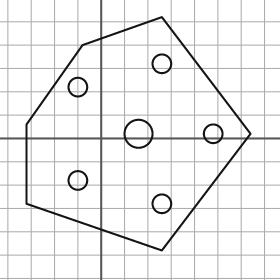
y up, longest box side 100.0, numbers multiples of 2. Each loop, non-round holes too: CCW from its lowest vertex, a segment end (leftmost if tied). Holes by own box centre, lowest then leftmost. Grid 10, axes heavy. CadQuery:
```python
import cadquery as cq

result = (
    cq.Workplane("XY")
    .moveTo(26.0, -48.0)
    .lineTo(64.0, 2.0)
    .lineTo(26.0, 52.0)
    .lineTo(-8.0, 40.0)
    .lineTo(-32.0, 6.0)
    .lineTo(-32.0, -28.0)
    .close()
    .moveTo(26.0, -28.0)
    .circle(4.0)
    .moveTo(-10.0, -18.0)
    .circle(4.0)
    .moveTo(16.0, 2.0)
    .circle(6.0)
    .moveTo(48.0, 2.0)
    .circle(4.0)
    .moveTo(-10.0, 22.0)
    .circle(4.0)
    .moveTo(26.0, 32.0)
    .circle(4.0)
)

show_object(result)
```